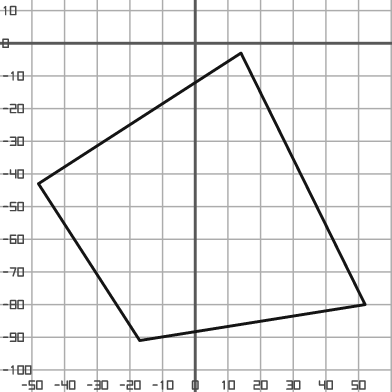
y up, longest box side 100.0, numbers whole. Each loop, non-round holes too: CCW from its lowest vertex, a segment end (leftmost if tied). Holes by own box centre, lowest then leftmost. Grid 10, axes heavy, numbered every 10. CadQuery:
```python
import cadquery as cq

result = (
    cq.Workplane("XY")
    .moveTo(-17.0, -91.0)
    .lineTo(52.0, -80.0)
    .lineTo(14.0, -3.0)
    .lineTo(-48.0, -43.0)
    .close()
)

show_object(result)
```